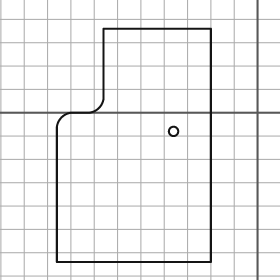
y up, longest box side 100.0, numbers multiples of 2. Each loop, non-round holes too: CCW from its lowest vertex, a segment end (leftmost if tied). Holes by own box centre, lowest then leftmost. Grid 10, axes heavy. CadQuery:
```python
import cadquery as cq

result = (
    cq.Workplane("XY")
    .moveTo(-86.0, -64.0)
    .lineTo(-20.0, -64.0)
    .lineTo(-20.0, 36.0)
    .lineTo(-66.0, 36.0)
    .lineTo(-66.0, 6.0)
    .threePointArc((-68.0, 2.0), (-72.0, 0.0))
    .lineTo(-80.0, 0.0)
    .threePointArc((-84.0, -2.0), (-86.0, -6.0))
    .close()
    .moveTo(-36.0, -8.0)
    .circle(2.0)
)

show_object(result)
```